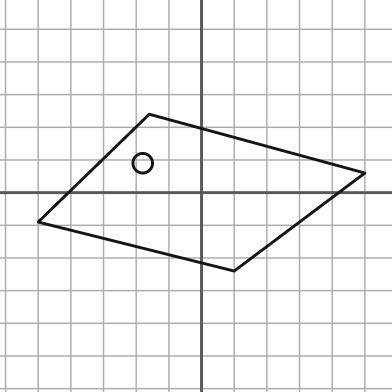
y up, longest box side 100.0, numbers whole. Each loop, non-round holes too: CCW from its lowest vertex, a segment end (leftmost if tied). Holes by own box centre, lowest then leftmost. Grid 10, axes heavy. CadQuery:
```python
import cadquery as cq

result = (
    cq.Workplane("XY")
    .moveTo(10.0, -24.0)
    .lineTo(50.0, 6.0)
    .lineTo(-16.0, 24.0)
    .lineTo(-50.0, -9.0)
    .close()
    .moveTo(-18.0, 9.0)
    .circle(3.0)
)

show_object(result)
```